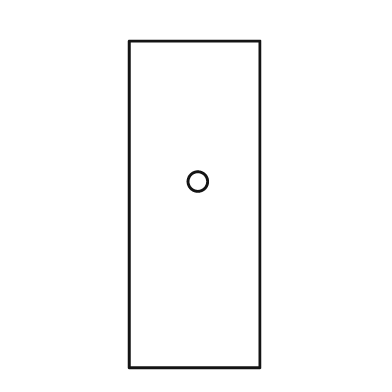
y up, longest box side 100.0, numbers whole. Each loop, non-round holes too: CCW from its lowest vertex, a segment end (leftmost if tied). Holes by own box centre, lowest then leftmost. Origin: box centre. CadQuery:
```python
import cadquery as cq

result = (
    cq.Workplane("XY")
    .moveTo(-20.0, -50.0)
    .lineTo(20.0, -50.0)
    .lineTo(20.0, 50.0)
    .lineTo(-20.0, 50.0)
    .close()
    .moveTo(1.0, 7.0)
    .circle(3.0)
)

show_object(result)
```